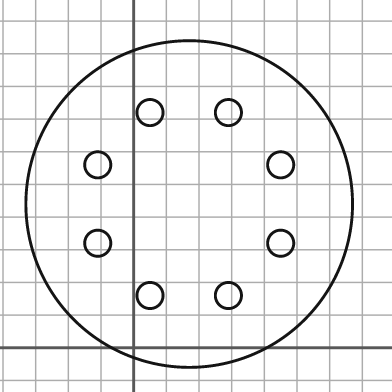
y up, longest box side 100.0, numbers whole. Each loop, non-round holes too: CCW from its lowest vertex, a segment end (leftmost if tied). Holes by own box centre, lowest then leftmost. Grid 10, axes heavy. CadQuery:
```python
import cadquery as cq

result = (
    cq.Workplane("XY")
    .moveTo(17.0, 44.0)
    .circle(50.0)
    .moveTo(5.0, 16.0)
    .circle(4.0)
    .moveTo(29.0, 16.0)
    .circle(4.0)
    .moveTo(-11.0, 32.0)
    .circle(4.0)
    .moveTo(45.0, 32.0)
    .circle(4.0)
    .moveTo(-11.0, 56.0)
    .circle(4.0)
    .moveTo(45.0, 56.0)
    .circle(4.0)
    .moveTo(5.0, 72.0)
    .circle(4.0)
    .moveTo(29.0, 72.0)
    .circle(4.0)
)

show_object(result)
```